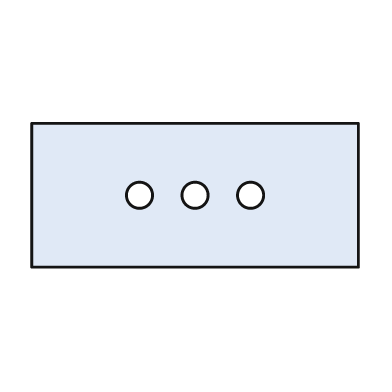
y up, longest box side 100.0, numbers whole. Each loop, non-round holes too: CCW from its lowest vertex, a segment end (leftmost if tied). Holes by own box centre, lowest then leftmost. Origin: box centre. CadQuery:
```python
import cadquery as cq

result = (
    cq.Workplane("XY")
    .moveTo(-50.0, -22.0)
    .lineTo(50.0, -22.0)
    .lineTo(50.0, 22.0)
    .lineTo(-50.0, 22.0)
    .close()
    .moveTo(-17.0, 0.0)
    .circle(4.0)
    .moveTo(0.0, 0.0)
    .circle(4.0)
    .moveTo(17.0, 0.0)
    .circle(4.0)
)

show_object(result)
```